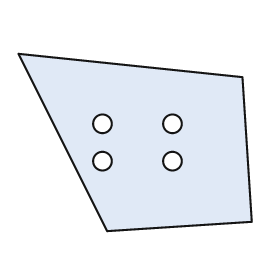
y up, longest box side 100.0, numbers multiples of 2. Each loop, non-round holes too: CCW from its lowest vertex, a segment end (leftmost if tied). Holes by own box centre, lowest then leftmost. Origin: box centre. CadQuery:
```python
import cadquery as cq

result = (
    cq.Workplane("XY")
    .moveTo(-12.0, -38.0)
    .lineTo(50.0, -34.0)
    .lineTo(46.0, 28.0)
    .lineTo(-50.0, 38.0)
    .close()
    .moveTo(-14.0, -8.0)
    .circle(4.0)
    .moveTo(16.0, -8.0)
    .circle(4.0)
    .moveTo(-14.0, 8.0)
    .circle(4.0)
    .moveTo(16.0, 8.0)
    .circle(4.0)
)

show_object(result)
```